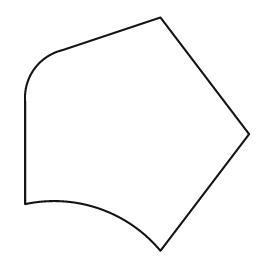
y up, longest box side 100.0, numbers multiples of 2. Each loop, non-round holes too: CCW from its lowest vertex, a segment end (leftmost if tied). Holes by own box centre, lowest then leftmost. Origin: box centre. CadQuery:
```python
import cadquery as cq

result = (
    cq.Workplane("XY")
    .moveTo(10.0, -50.0)
    .lineTo(48.0, 0.0)
    .lineTo(10.0, 50.0)
    .lineTo(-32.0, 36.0)
    .threePointArc((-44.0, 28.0), (-48.0, 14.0))
    .lineTo(-48.0, -30.0)
    .threePointArc((-16.0, -32.0), (10.0, -50.0))
    .close()
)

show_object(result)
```